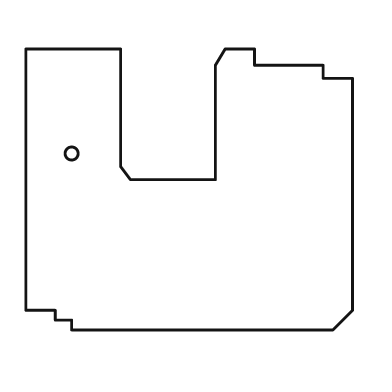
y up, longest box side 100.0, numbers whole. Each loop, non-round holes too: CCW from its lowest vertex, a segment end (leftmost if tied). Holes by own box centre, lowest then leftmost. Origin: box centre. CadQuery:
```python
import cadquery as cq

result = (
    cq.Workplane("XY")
    .moveTo(-36.0, -43.0)
    .lineTo(44.0, -43.0)
    .lineTo(50.0, -37.0)
    .lineTo(50.0, 34.0)
    .lineTo(41.0, 34.0)
    .lineTo(41.0, 38.0)
    .lineTo(20.0, 38.0)
    .lineTo(20.0, 43.0)
    .lineTo(11.0, 43.0)
    .lineTo(8.0, 38.0)
    .lineTo(8.0, 3.0)
    .lineTo(-18.0, 3.0)
    .lineTo(-21.0, 7.0)
    .lineTo(-21.0, 43.0)
    .lineTo(-50.0, 43.0)
    .lineTo(-50.0, -37.0)
    .lineTo(-41.0, -37.0)
    .lineTo(-41.0, -40.0)
    .lineTo(-36.0, -40.0)
    .close()
    .moveTo(-36.0, 11.0)
    .circle(2.0)
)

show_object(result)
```